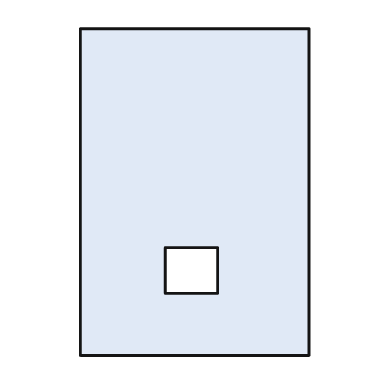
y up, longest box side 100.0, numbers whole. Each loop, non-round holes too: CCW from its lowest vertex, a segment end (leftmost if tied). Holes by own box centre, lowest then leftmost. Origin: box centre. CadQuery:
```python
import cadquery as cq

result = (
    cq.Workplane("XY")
    .moveTo(-35.0, -50.0)
    .lineTo(35.0, -50.0)
    .lineTo(35.0, 50.0)
    .lineTo(-35.0, 50.0)
    .close()
    .moveTo(-9.0, -31.0)
    .lineTo(7.0, -31.0)
    .lineTo(7.0, -17.0)
    .lineTo(-9.0, -17.0)
    .close()
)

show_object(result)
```